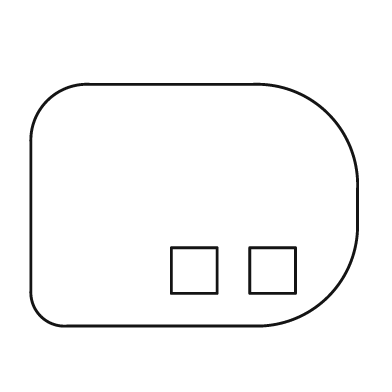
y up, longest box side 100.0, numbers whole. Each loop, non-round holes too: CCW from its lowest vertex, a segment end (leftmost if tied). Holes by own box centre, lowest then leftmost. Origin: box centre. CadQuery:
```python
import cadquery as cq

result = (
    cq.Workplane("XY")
    .moveTo(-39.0, -37.0)
    .lineTo(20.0, -37.0)
    .threePointArc((41.0, -28.0), (50.0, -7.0))
    .lineTo(50.0, 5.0)
    .threePointArc((41.0, 28.0), (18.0, 37.0))
    .lineTo(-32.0, 37.0)
    .threePointArc((-45.0, 32.0), (-50.0, 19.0))
    .lineTo(-50.0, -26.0)
    .threePointArc((-47.0, -34.0), (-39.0, -37.0))
    .close()
    .moveTo(-7.0, -27.0)
    .lineTo(7.0, -27.0)
    .lineTo(7.0, -13.0)
    .lineTo(-7.0, -13.0)
    .close()
    .moveTo(17.0, -27.0)
    .lineTo(31.0, -27.0)
    .lineTo(31.0, -13.0)
    .lineTo(17.0, -13.0)
    .close()
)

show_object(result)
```